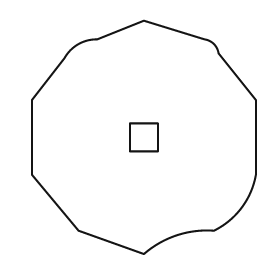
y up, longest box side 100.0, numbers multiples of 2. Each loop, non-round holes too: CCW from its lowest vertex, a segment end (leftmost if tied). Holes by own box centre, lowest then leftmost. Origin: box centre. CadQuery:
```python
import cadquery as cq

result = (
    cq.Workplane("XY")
    .moveTo(0.0, -50.0)
    .threePointArc((14.0, -42.0), (30.0, -40.0))
    .threePointArc((42.0, -30.0), (48.0, -16.0))
    .lineTo(48.0, 16.0)
    .lineTo(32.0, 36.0)
    .threePointArc((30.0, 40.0), (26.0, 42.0))
    .lineTo(0.0, 50.0)
    .lineTo(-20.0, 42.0)
    .threePointArc((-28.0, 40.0), (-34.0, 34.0))
    .lineTo(-48.0, 16.0)
    .lineTo(-48.0, -16.0)
    .lineTo(-28.0, -40.0)
    .close()
    .moveTo(-6.0, -6.0)
    .lineTo(6.0, -6.0)
    .lineTo(6.0, 6.0)
    .lineTo(-6.0, 6.0)
    .close()
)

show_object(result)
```